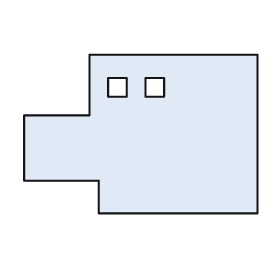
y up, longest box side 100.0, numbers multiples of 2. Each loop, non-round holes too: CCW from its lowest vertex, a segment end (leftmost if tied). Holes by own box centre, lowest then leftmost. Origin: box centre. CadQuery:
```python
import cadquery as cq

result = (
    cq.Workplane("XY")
    .moveTo(-18.0, -34.0)
    .lineTo(50.0, -34.0)
    .lineTo(50.0, 34.0)
    .lineTo(-22.0, 34.0)
    .lineTo(-22.0, 8.0)
    .lineTo(-50.0, 8.0)
    .lineTo(-50.0, -20.0)
    .lineTo(-18.0, -20.0)
    .close()
    .moveTo(-14.0, 16.0)
    .lineTo(-6.0, 16.0)
    .lineTo(-6.0, 24.0)
    .lineTo(-14.0, 24.0)
    .close()
    .moveTo(2.0, 16.0)
    .lineTo(10.0, 16.0)
    .lineTo(10.0, 24.0)
    .lineTo(2.0, 24.0)
    .close()
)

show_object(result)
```